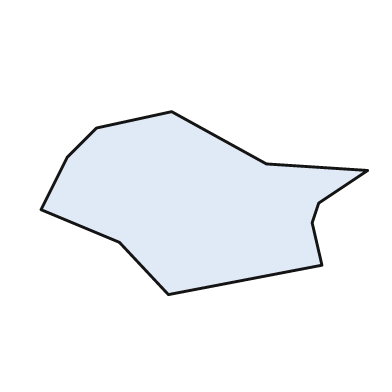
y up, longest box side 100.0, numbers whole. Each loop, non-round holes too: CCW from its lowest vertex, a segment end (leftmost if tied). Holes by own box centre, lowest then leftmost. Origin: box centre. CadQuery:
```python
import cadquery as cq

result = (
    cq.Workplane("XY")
    .moveTo(-11.0, -28.0)
    .lineTo(36.0, -19.0)
    .lineTo(33.0, -6.0)
    .lineTo(35.0, 0.0)
    .lineTo(50.0, 10.0)
    .lineTo(19.0, 12.0)
    .lineTo(-10.0, 28.0)
    .lineTo(-33.0, 23.0)
    .lineTo(-42.0, 14.0)
    .lineTo(-50.0, -2.0)
    .lineTo(-26.0, -12.0)
    .close()
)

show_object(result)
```